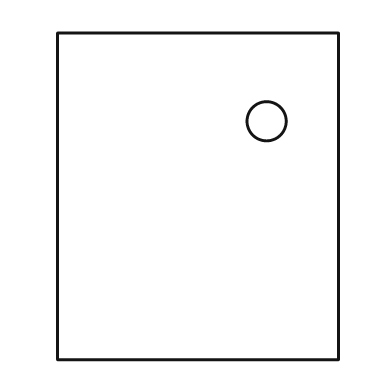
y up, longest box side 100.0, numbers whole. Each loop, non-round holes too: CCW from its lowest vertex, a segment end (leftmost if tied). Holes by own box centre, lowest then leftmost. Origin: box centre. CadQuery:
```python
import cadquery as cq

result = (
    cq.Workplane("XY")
    .moveTo(-43.0, -50.0)
    .lineTo(43.0, -50.0)
    .lineTo(43.0, 50.0)
    .lineTo(-43.0, 50.0)
    .close()
    .moveTo(21.0, 23.0)
    .circle(6.0)
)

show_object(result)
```